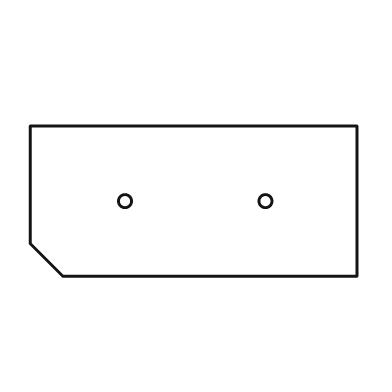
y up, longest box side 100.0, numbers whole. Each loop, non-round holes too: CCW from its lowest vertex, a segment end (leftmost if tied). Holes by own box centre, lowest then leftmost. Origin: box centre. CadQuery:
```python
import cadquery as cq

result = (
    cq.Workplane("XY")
    .moveTo(-40.0, -23.0)
    .lineTo(50.0, -23.0)
    .lineTo(50.0, 23.0)
    .lineTo(-50.0, 23.0)
    .lineTo(-50.0, -13.0)
    .close()
    .moveTo(-21.0, 0.0)
    .circle(2.0)
    .moveTo(22.0, 0.0)
    .circle(2.0)
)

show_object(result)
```